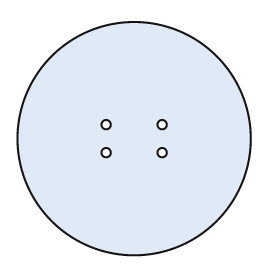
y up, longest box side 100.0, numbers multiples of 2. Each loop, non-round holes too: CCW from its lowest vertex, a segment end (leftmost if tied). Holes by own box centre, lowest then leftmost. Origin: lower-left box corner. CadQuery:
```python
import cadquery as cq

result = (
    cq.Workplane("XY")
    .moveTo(50.0, 50.0)
    .circle(50.0)
    .moveTo(38.0, 44.0)
    .circle(2.0)
    .moveTo(62.0, 44.0)
    .circle(2.0)
    .moveTo(38.0, 56.0)
    .circle(2.0)
    .moveTo(62.0, 56.0)
    .circle(2.0)
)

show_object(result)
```